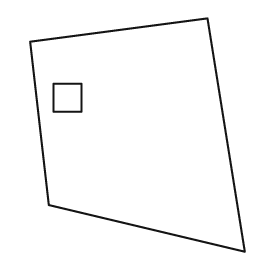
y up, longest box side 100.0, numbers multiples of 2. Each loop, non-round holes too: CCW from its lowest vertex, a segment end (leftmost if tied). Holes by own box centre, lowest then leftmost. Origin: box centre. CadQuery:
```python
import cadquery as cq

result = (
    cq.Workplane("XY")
    .moveTo(46.0, -50.0)
    .lineTo(30.0, 50.0)
    .lineTo(-46.0, 40.0)
    .lineTo(-38.0, -30.0)
    .close()
    .moveTo(-36.0, 10.0)
    .lineTo(-24.0, 10.0)
    .lineTo(-24.0, 22.0)
    .lineTo(-36.0, 22.0)
    .close()
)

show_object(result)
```